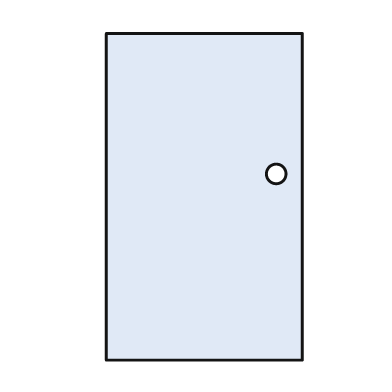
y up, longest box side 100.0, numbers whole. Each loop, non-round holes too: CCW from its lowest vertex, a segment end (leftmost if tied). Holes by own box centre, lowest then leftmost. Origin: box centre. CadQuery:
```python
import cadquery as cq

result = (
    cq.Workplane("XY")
    .moveTo(-30.0, -50.0)
    .lineTo(30.0, -50.0)
    .lineTo(30.0, 50.0)
    .lineTo(-30.0, 50.0)
    .close()
    .moveTo(22.0, 7.0)
    .circle(3.0)
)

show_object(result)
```